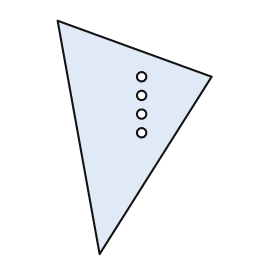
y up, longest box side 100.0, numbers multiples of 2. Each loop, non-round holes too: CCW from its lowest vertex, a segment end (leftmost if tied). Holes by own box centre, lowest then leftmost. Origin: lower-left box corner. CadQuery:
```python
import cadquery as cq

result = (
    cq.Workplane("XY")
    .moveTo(18.0, 0.0)
    .lineTo(66.0, 76.0)
    .lineTo(0.0, 100.0)
    .close()
    .moveTo(36.0, 52.0)
    .circle(2.0)
    .moveTo(36.0, 60.0)
    .circle(2.0)
    .moveTo(36.0, 68.0)
    .circle(2.0)
    .moveTo(36.0, 76.0)
    .circle(2.0)
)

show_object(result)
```